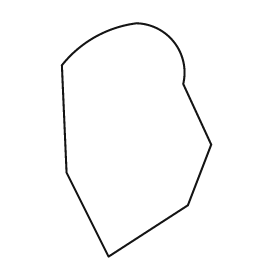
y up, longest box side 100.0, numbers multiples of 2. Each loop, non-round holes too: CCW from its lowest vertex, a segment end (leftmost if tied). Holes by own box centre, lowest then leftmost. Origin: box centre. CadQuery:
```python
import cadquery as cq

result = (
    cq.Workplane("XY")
    .moveTo(-12.0, -50.0)
    .lineTo(22.0, -28.0)
    .lineTo(32.0, -2.0)
    .lineTo(20.0, 24.0)
    .threePointArc((16.0, 42.0), (0.0, 50.0))
    .threePointArc((-18.0, 44.0), (-32.0, 32.0))
    .lineTo(-30.0, -14.0)
    .close()
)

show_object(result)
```